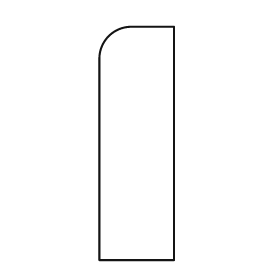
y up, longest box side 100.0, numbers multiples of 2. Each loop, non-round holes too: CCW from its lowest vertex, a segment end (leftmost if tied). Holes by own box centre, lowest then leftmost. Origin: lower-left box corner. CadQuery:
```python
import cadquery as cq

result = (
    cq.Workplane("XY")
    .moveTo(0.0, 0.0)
    .lineTo(32.0, 0.0)
    .lineTo(32.0, 100.0)
    .lineTo(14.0, 100.0)
    .threePointArc((4.0, 96.0), (0.0, 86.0))
    .close()
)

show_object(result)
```